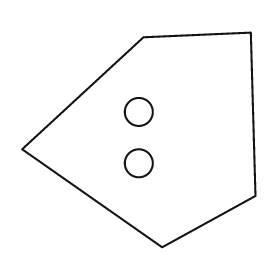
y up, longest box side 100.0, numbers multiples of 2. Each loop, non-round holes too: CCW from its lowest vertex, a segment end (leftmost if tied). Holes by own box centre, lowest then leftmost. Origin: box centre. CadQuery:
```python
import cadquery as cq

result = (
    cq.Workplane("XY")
    .moveTo(10.0, -46.0)
    .lineTo(50.0, -24.0)
    .lineTo(48.0, 46.0)
    .lineTo(2.0, 44.0)
    .lineTo(-50.0, -4.0)
    .close()
    .moveTo(0.0, -10.0)
    .circle(6.0)
    .moveTo(0.0, 12.0)
    .circle(6.0)
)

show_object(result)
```